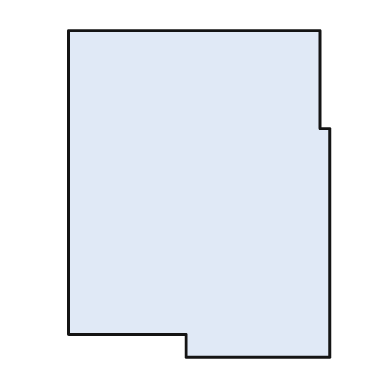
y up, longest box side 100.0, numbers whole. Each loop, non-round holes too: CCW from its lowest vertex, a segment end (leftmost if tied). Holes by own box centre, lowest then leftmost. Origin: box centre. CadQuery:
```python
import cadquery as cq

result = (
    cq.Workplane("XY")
    .moveTo(-4.0, -50.0)
    .lineTo(40.0, -50.0)
    .lineTo(40.0, 20.0)
    .lineTo(37.0, 20.0)
    .lineTo(37.0, 50.0)
    .lineTo(-40.0, 50.0)
    .lineTo(-40.0, -43.0)
    .lineTo(-4.0, -43.0)
    .close()
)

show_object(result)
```